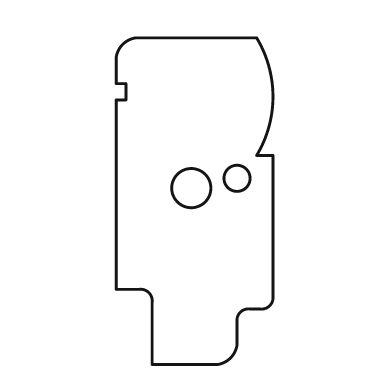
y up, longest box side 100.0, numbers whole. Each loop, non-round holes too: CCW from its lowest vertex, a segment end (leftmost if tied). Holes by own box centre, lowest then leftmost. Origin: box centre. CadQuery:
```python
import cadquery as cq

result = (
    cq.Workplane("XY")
    .moveTo(-13.0, -50.0)
    .lineTo(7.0, -50.0)
    .threePointArc((11.0, -48.0), (13.0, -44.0))
    .lineTo(13.0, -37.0)
    .threePointArc((14.0, -34.0), (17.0, -33.0))
    .lineTo(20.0, -33.0)
    .threePointArc((23.0, -32.0), (24.0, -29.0))
    .lineTo(24.0, 14.0)
    .lineTo(19.0, 14.0)
    .threePointArc((24.0, 32.0), (19.0, 50.0))
    .lineTo(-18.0, 50.0)
    .threePointArc((-22.0, 48.0), (-24.0, 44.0))
    .lineTo(-24.0, 36.0)
    .lineTo(-21.0, 36.0)
    .lineTo(-21.0, 31.0)
    .lineTo(-24.0, 31.0)
    .lineTo(-24.0, -27.0)
    .lineTo(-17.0, -27.0)
    .threePointArc((-14.0, -28.0), (-13.0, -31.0))
    .close()
    .moveTo(-1.0, 4.0)
    .circle(6.0)
    .moveTo(13.0, 7.0)
    .circle(4.0)
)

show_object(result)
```